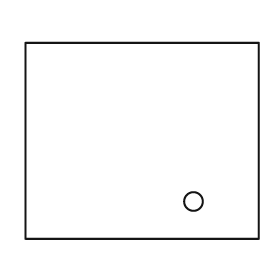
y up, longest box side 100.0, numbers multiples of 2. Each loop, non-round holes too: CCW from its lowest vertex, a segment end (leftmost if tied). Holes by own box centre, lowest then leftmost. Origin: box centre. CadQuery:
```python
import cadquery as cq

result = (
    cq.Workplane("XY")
    .moveTo(-50.0, -42.0)
    .lineTo(50.0, -42.0)
    .lineTo(50.0, 42.0)
    .lineTo(-50.0, 42.0)
    .close()
    .moveTo(22.0, -26.0)
    .circle(4.0)
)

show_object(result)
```